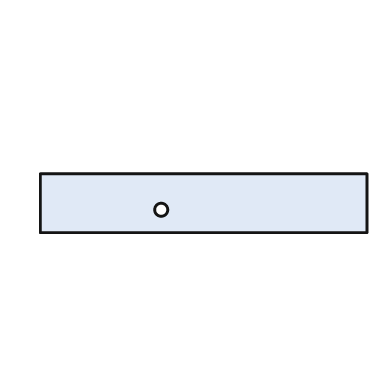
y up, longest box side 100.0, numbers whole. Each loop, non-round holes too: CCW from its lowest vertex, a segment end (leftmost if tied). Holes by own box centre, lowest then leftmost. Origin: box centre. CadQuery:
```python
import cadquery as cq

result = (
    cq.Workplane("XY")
    .moveTo(-50.0, -9.0)
    .lineTo(50.0, -9.0)
    .lineTo(50.0, 9.0)
    .lineTo(-50.0, 9.0)
    .close()
    .moveTo(-13.0, -2.0)
    .circle(2.0)
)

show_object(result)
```